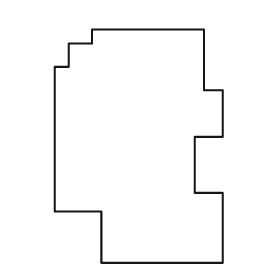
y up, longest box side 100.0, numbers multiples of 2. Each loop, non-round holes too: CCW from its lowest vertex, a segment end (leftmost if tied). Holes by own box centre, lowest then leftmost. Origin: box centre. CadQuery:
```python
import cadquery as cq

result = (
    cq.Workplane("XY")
    .moveTo(-16.0, -50.0)
    .lineTo(36.0, -50.0)
    .lineTo(36.0, -20.0)
    .lineTo(24.0, -20.0)
    .lineTo(24.0, 4.0)
    .lineTo(36.0, 4.0)
    .lineTo(36.0, 24.0)
    .lineTo(28.0, 24.0)
    .lineTo(28.0, 50.0)
    .lineTo(-20.0, 50.0)
    .lineTo(-20.0, 44.0)
    .lineTo(-30.0, 44.0)
    .lineTo(-30.0, 34.0)
    .lineTo(-36.0, 34.0)
    .lineTo(-36.0, -28.0)
    .lineTo(-16.0, -28.0)
    .close()
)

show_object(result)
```